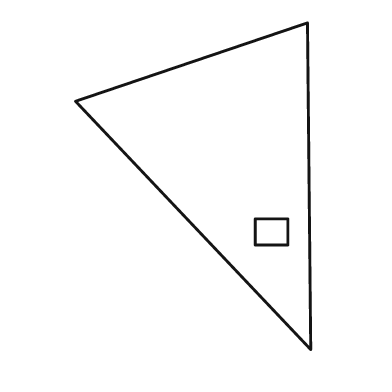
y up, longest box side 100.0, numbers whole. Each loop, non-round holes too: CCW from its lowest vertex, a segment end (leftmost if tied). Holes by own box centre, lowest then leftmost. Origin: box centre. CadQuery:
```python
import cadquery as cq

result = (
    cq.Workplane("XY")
    .moveTo(36.0, -50.0)
    .lineTo(35.0, 50.0)
    .lineTo(-36.0, 26.0)
    .close()
    .moveTo(19.0, -18.0)
    .lineTo(29.0, -18.0)
    .lineTo(29.0, -10.0)
    .lineTo(19.0, -10.0)
    .close()
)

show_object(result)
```